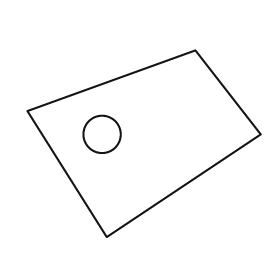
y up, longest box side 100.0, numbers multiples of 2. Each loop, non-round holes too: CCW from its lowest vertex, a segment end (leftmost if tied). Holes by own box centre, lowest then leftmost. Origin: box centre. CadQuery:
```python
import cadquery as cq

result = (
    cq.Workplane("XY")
    .moveTo(-16.0, -40.0)
    .lineTo(50.0, 4.0)
    .lineTo(22.0, 40.0)
    .lineTo(-50.0, 14.0)
    .close()
    .moveTo(-18.0, 4.0)
    .circle(8.0)
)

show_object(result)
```